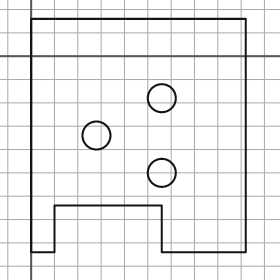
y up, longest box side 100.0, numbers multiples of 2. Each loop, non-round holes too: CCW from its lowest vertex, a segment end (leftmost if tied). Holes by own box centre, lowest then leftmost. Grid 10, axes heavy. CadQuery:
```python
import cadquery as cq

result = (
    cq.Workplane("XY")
    .moveTo(0.0, -84.0)
    .lineTo(10.0, -84.0)
    .lineTo(10.0, -64.0)
    .lineTo(56.0, -64.0)
    .lineTo(56.0, -84.0)
    .lineTo(92.0, -84.0)
    .lineTo(92.0, 16.0)
    .lineTo(0.0, 16.0)
    .close()
    .moveTo(56.0, -50.0)
    .circle(6.0)
    .moveTo(28.0, -34.0)
    .circle(6.0)
    .moveTo(56.0, -18.0)
    .circle(6.0)
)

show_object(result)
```